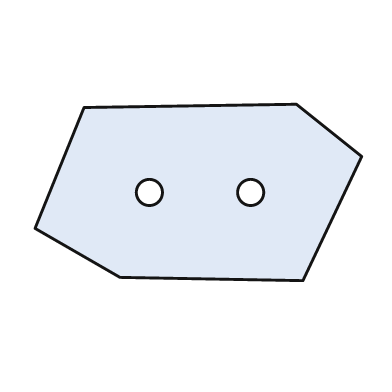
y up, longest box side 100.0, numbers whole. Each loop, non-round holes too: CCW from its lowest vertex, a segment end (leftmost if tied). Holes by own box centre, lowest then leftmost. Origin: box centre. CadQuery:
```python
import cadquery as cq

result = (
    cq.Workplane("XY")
    .moveTo(32.0, -27.0)
    .lineTo(50.0, 11.0)
    .lineTo(30.0, 27.0)
    .lineTo(-35.0, 26.0)
    .lineTo(-50.0, -11.0)
    .lineTo(-24.0, -26.0)
    .close()
    .moveTo(-15.0, 0.0)
    .circle(4.0)
    .moveTo(16.0, 0.0)
    .circle(4.0)
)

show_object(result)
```